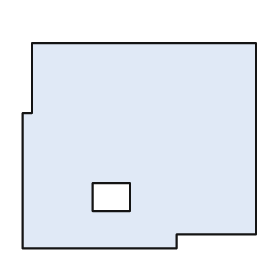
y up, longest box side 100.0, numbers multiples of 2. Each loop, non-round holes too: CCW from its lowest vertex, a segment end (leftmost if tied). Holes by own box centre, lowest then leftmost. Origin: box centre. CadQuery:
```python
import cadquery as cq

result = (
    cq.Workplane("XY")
    .moveTo(-50.0, -44.0)
    .lineTo(16.0, -44.0)
    .lineTo(16.0, -38.0)
    .lineTo(50.0, -38.0)
    .lineTo(50.0, 44.0)
    .lineTo(-46.0, 44.0)
    .lineTo(-46.0, 14.0)
    .lineTo(-50.0, 14.0)
    .close()
    .moveTo(-20.0, -28.0)
    .lineTo(-4.0, -28.0)
    .lineTo(-4.0, -16.0)
    .lineTo(-20.0, -16.0)
    .close()
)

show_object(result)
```